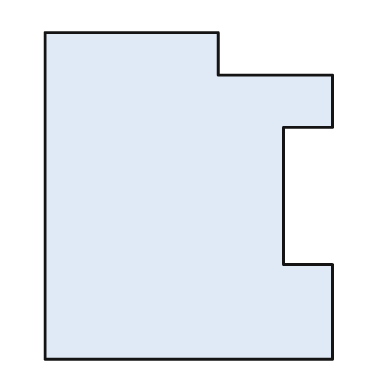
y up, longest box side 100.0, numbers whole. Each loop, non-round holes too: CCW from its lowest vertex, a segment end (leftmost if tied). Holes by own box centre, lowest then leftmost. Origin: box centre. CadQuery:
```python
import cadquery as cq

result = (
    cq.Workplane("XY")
    .moveTo(-44.0, -50.0)
    .lineTo(44.0, -50.0)
    .lineTo(44.0, -21.0)
    .lineTo(29.0, -21.0)
    .lineTo(29.0, 21.0)
    .lineTo(44.0, 21.0)
    .lineTo(44.0, 37.0)
    .lineTo(9.0, 37.0)
    .lineTo(9.0, 50.0)
    .lineTo(-44.0, 50.0)
    .close()
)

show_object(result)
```